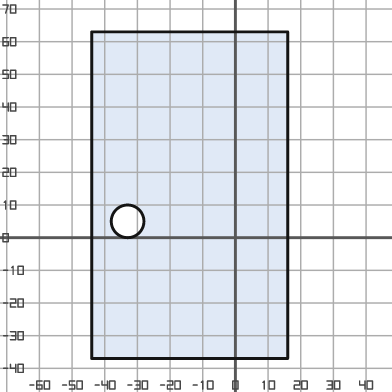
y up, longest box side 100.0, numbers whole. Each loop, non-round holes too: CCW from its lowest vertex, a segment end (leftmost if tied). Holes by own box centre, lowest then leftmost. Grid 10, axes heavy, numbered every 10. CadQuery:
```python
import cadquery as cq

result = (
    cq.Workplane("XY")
    .moveTo(-44.0, -37.0)
    .lineTo(16.0, -37.0)
    .lineTo(16.0, 63.0)
    .lineTo(-44.0, 63.0)
    .close()
    .moveTo(-33.0, 5.0)
    .circle(5.0)
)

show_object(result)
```